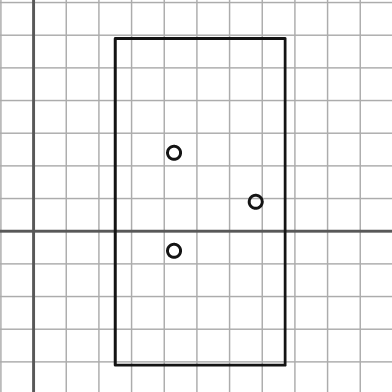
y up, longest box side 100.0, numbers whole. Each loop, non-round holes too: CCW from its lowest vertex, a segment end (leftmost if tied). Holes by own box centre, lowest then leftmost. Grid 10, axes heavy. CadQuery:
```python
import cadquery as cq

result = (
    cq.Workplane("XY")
    .moveTo(25.0, -41.0)
    .lineTo(77.0, -41.0)
    .lineTo(77.0, 59.0)
    .lineTo(25.0, 59.0)
    .close()
    .moveTo(43.0, -6.0)
    .circle(2.0)
    .moveTo(68.0, 9.0)
    .circle(2.0)
    .moveTo(43.0, 24.0)
    .circle(2.0)
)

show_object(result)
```